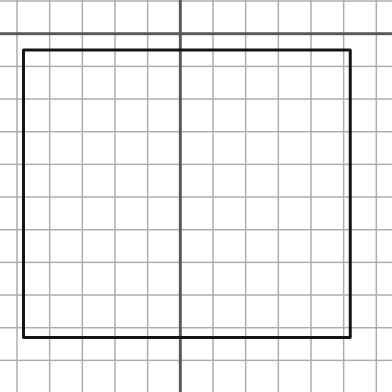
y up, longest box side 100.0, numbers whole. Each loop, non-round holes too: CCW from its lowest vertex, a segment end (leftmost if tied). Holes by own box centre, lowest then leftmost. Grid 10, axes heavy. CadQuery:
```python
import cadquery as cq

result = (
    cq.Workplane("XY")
    .moveTo(-48.0, -93.0)
    .lineTo(52.0, -93.0)
    .lineTo(52.0, -5.0)
    .lineTo(-48.0, -5.0)
    .close()
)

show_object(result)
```